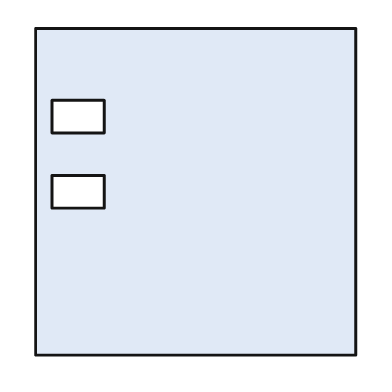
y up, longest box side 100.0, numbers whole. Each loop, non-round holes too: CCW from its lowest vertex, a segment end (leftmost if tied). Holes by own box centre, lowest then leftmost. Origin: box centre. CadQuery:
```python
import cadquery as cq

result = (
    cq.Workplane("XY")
    .moveTo(-49.0, -50.0)
    .lineTo(49.0, -50.0)
    .lineTo(49.0, 50.0)
    .lineTo(-49.0, 50.0)
    .close()
    .moveTo(-44.0, -5.0)
    .lineTo(-28.0, -5.0)
    .lineTo(-28.0, 5.0)
    .lineTo(-44.0, 5.0)
    .close()
    .moveTo(-44.0, 18.0)
    .lineTo(-28.0, 18.0)
    .lineTo(-28.0, 28.0)
    .lineTo(-44.0, 28.0)
    .close()
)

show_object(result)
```